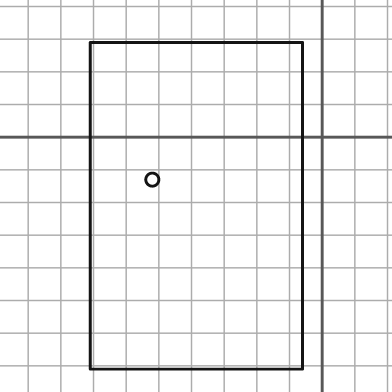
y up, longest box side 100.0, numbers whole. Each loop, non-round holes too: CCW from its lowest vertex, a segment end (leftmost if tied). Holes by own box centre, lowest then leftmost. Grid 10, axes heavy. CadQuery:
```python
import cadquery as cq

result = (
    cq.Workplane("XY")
    .moveTo(-71.0, -71.0)
    .lineTo(-6.0, -71.0)
    .lineTo(-6.0, 29.0)
    .lineTo(-71.0, 29.0)
    .close()
    .moveTo(-52.0, -13.0)
    .circle(2.0)
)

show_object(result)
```